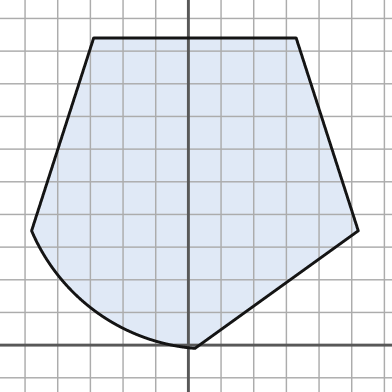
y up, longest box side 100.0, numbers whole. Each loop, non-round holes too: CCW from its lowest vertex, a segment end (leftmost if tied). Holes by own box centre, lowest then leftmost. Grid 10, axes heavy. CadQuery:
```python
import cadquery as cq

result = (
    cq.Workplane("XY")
    .moveTo(2.0, -1.0)
    .lineTo(52.0, 35.0)
    .lineTo(33.0, 94.0)
    .lineTo(-29.0, 94.0)
    .lineTo(-48.0, 35.0)
    .threePointArc((-28.0, 10.0), (2.0, -1.0))
    .close()
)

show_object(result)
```